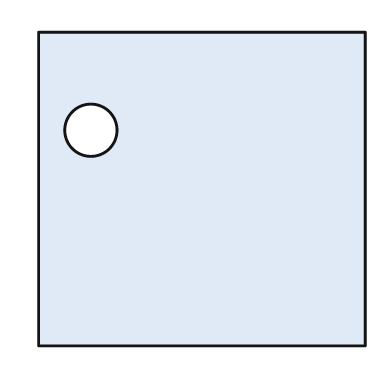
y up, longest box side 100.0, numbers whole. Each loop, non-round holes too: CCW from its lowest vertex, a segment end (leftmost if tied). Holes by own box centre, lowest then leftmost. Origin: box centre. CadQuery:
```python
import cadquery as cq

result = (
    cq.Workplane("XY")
    .moveTo(-50.0, -48.0)
    .lineTo(50.0, -48.0)
    .lineTo(50.0, 48.0)
    .lineTo(-50.0, 48.0)
    .close()
    .moveTo(-34.0, 18.0)
    .circle(8.0)
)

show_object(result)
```